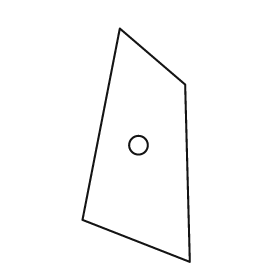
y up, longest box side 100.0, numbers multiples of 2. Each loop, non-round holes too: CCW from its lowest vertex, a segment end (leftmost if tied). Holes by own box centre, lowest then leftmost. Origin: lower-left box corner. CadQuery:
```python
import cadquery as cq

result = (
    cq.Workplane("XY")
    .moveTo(46.0, 0.0)
    .lineTo(44.0, 76.0)
    .lineTo(16.0, 100.0)
    .lineTo(0.0, 18.0)
    .close()
    .moveTo(24.0, 50.0)
    .circle(4.0)
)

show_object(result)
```